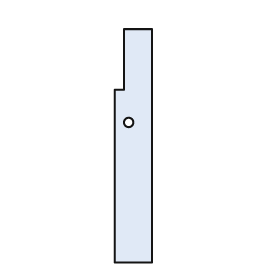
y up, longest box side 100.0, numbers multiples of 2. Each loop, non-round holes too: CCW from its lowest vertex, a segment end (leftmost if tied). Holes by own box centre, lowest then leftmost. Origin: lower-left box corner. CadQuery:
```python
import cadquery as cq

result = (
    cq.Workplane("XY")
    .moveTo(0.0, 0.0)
    .lineTo(16.0, 0.0)
    .lineTo(16.0, 100.0)
    .lineTo(4.0, 100.0)
    .lineTo(4.0, 74.0)
    .lineTo(0.0, 74.0)
    .close()
    .moveTo(6.0, 60.0)
    .circle(2.0)
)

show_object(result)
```